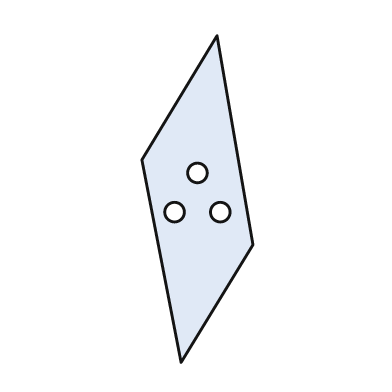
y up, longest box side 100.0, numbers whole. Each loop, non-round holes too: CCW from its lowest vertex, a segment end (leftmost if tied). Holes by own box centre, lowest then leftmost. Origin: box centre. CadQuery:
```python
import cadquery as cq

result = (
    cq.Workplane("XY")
    .moveTo(-5.0, -50.0)
    .lineTo(17.0, -14.0)
    .lineTo(6.0, 50.0)
    .lineTo(-17.0, 12.0)
    .close()
    .moveTo(-7.0, -4.0)
    .circle(3.0)
    .moveTo(7.0, -4.0)
    .circle(3.0)
    .moveTo(0.0, 8.0)
    .circle(3.0)
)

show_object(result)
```